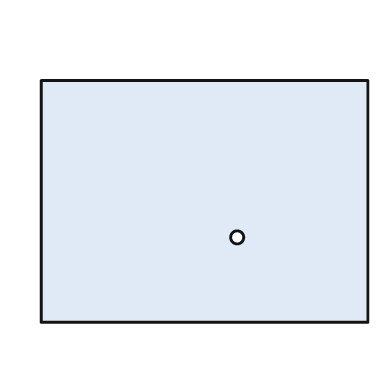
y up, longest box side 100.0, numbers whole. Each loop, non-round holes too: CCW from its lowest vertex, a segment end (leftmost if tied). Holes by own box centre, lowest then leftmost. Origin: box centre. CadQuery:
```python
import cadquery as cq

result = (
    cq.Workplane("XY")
    .moveTo(-50.0, -37.0)
    .lineTo(50.0, -37.0)
    .lineTo(50.0, 37.0)
    .lineTo(-50.0, 37.0)
    .close()
    .moveTo(10.0, -11.0)
    .circle(2.0)
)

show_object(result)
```